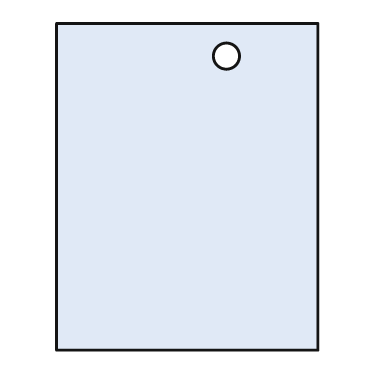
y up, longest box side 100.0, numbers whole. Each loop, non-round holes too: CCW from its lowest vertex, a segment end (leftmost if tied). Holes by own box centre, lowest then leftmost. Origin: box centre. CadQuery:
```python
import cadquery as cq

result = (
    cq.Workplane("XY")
    .moveTo(-40.0, -50.0)
    .lineTo(40.0, -50.0)
    .lineTo(40.0, 50.0)
    .lineTo(-40.0, 50.0)
    .close()
    .moveTo(12.0, 40.0)
    .circle(4.0)
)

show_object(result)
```